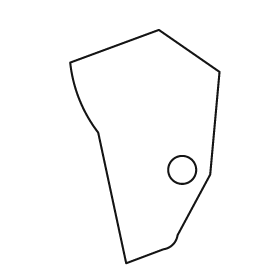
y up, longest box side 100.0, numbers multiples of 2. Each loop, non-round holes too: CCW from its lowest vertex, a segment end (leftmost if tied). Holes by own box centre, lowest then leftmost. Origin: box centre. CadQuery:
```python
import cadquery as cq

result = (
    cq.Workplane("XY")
    .moveTo(-8.0, -50.0)
    .lineTo(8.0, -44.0)
    .threePointArc((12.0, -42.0), (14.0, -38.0))
    .lineTo(28.0, -12.0)
    .lineTo(32.0, 32.0)
    .lineTo(6.0, 50.0)
    .lineTo(-32.0, 36.0)
    .threePointArc((-28.0, 20.0), (-20.0, 6.0))
    .close()
    .moveTo(16.0, -10.0)
    .circle(6.0)
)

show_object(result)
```